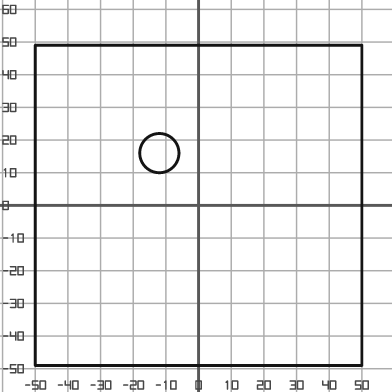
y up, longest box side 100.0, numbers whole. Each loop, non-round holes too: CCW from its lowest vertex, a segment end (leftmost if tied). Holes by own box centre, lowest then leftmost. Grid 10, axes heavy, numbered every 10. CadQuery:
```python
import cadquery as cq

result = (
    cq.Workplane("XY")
    .moveTo(-50.0, -49.0)
    .lineTo(50.0, -49.0)
    .lineTo(50.0, 49.0)
    .lineTo(-50.0, 49.0)
    .close()
    .moveTo(-12.0, 16.0)
    .circle(6.0)
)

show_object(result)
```